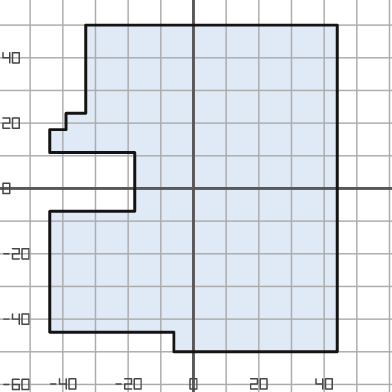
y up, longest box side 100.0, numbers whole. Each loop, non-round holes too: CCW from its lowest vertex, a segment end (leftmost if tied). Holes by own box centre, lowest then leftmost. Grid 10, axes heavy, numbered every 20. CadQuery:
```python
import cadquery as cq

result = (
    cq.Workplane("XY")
    .moveTo(-6.0, -50.0)
    .lineTo(44.0, -50.0)
    .lineTo(44.0, 50.0)
    .lineTo(-33.0, 50.0)
    .lineTo(-33.0, 23.0)
    .lineTo(-39.0, 23.0)
    .lineTo(-39.0, 18.0)
    .lineTo(-44.0, 18.0)
    .lineTo(-44.0, 11.0)
    .lineTo(-18.0, 11.0)
    .lineTo(-18.0, -7.0)
    .lineTo(-44.0, -7.0)
    .lineTo(-44.0, -44.0)
    .lineTo(-6.0, -44.0)
    .close()
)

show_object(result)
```